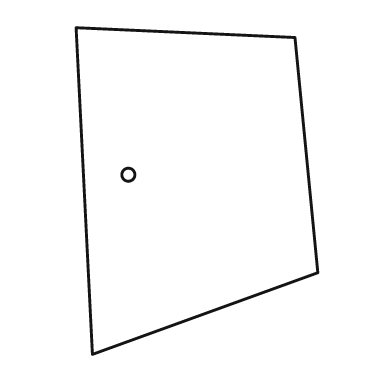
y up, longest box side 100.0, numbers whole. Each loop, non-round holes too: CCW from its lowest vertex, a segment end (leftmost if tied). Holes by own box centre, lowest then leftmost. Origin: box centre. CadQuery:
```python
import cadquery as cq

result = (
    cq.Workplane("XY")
    .moveTo(-32.0, -50.0)
    .lineTo(37.0, -25.0)
    .lineTo(30.0, 47.0)
    .lineTo(-37.0, 50.0)
    .close()
    .moveTo(-21.0, 5.0)
    .circle(2.0)
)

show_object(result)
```